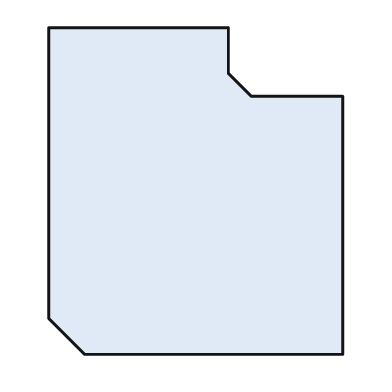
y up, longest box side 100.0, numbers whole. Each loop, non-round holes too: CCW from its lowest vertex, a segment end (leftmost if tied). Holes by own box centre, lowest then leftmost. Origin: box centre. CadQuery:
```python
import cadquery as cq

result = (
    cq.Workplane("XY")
    .moveTo(-34.0, -50.0)
    .lineTo(45.0, -50.0)
    .lineTo(45.0, 29.0)
    .lineTo(17.0, 29.0)
    .lineTo(10.0, 36.0)
    .lineTo(10.0, 50.0)
    .lineTo(-45.0, 50.0)
    .lineTo(-45.0, -39.0)
    .close()
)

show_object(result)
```